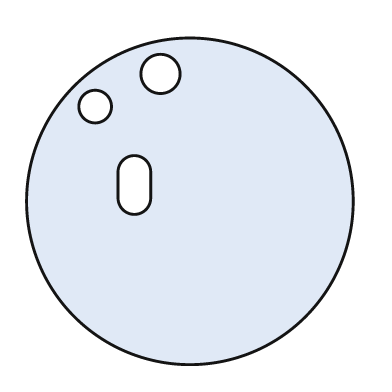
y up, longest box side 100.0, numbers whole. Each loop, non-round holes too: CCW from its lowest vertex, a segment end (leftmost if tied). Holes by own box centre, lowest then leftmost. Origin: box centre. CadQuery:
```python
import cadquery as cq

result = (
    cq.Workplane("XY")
    .moveTo(0.0, 0.0)
    .circle(50.0)
    .moveTo(-22.0, 1.0)
    .threePointArc((-17.0, -4.0), (-12.0, 1.0))
    .lineTo(-12.0, 9.0)
    .threePointArc((-17.0, 14.0), (-22.0, 9.0))
    .close()
    .moveTo(-29.0, 29.0)
    .circle(5.0)
    .moveTo(-9.0, 39.0)
    .circle(6.0)
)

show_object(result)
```